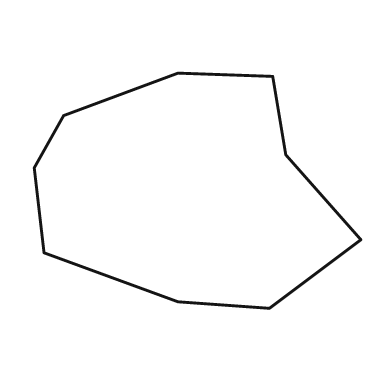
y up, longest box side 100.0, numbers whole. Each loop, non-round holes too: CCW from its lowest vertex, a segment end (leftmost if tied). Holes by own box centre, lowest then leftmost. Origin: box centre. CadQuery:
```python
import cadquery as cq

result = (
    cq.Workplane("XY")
    .moveTo(22.0, -36.0)
    .lineTo(50.0, -15.0)
    .lineTo(27.0, 11.0)
    .lineTo(23.0, 35.0)
    .lineTo(-6.0, 36.0)
    .lineTo(-41.0, 23.0)
    .lineTo(-50.0, 7.0)
    .lineTo(-47.0, -19.0)
    .lineTo(-6.0, -34.0)
    .close()
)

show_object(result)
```